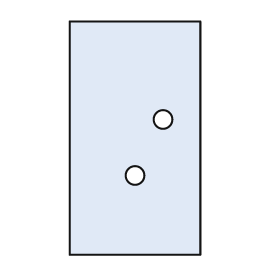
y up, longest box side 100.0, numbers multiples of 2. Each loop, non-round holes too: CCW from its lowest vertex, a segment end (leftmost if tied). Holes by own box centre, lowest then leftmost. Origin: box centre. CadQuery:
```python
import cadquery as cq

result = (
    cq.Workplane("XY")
    .moveTo(-28.0, -50.0)
    .lineTo(28.0, -50.0)
    .lineTo(28.0, 50.0)
    .lineTo(-28.0, 50.0)
    .close()
    .moveTo(0.0, -16.0)
    .circle(4.0)
    .moveTo(12.0, 8.0)
    .circle(4.0)
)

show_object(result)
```